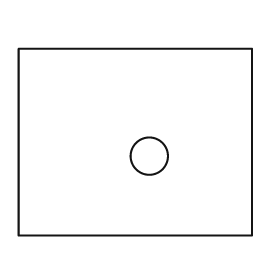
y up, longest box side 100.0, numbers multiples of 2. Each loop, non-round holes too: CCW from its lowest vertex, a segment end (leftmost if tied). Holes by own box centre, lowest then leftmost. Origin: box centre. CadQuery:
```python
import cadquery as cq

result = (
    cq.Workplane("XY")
    .moveTo(-50.0, -40.0)
    .lineTo(50.0, -40.0)
    .lineTo(50.0, 40.0)
    .lineTo(-50.0, 40.0)
    .close()
    .moveTo(6.0, -6.0)
    .circle(8.0)
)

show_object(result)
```